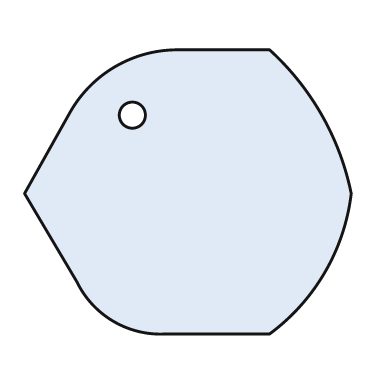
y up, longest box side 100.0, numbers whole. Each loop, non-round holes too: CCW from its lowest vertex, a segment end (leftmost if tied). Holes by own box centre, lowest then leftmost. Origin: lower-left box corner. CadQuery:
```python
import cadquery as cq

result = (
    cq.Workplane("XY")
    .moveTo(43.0, 0.0)
    .lineTo(75.0, 0.0)
    .threePointArc((92.0, 19.0), (100.0, 43.0))
    .threePointArc((91.0, 67.0), (75.0, 87.0))
    .lineTo(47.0, 87.0)
    .threePointArc((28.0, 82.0), (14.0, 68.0))
    .lineTo(0.0, 43.0)
    .lineTo(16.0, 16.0)
    .threePointArc((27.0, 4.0), (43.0, 0.0))
    .close()
    .moveTo(33.0, 67.0)
    .circle(4.0)
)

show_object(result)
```